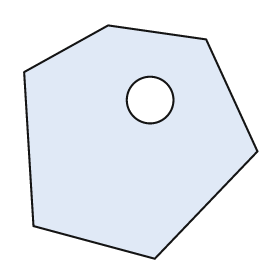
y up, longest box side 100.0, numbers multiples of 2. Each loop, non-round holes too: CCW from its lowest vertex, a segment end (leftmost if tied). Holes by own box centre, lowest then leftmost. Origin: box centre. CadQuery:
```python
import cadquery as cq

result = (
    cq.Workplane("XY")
    .moveTo(6.0, -50.0)
    .lineTo(50.0, -4.0)
    .lineTo(28.0, 44.0)
    .lineTo(-14.0, 50.0)
    .lineTo(-50.0, 30.0)
    .lineTo(-46.0, -36.0)
    .close()
    .moveTo(4.0, 18.0)
    .circle(10.0)
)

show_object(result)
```